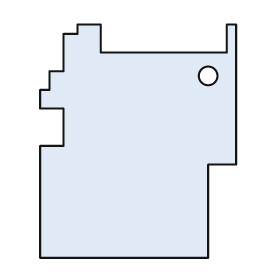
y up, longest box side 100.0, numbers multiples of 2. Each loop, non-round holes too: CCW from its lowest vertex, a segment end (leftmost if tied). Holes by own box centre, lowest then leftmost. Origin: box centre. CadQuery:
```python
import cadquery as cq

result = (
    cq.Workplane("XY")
    .moveTo(-42.0, -50.0)
    .lineTo(30.0, -50.0)
    .lineTo(30.0, -10.0)
    .lineTo(42.0, -10.0)
    .lineTo(42.0, 50.0)
    .lineTo(38.0, 50.0)
    .lineTo(38.0, 38.0)
    .lineTo(-16.0, 38.0)
    .lineTo(-16.0, 50.0)
    .lineTo(-26.0, 50.0)
    .lineTo(-26.0, 46.0)
    .lineTo(-32.0, 46.0)
    .lineTo(-32.0, 30.0)
    .lineTo(-38.0, 30.0)
    .lineTo(-38.0, 22.0)
    .lineTo(-42.0, 22.0)
    .lineTo(-42.0, 14.0)
    .lineTo(-32.0, 14.0)
    .lineTo(-32.0, -2.0)
    .lineTo(-42.0, -2.0)
    .close()
    .moveTo(30.0, 28.0)
    .circle(4.0)
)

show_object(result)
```